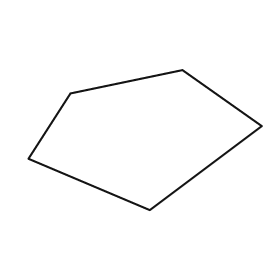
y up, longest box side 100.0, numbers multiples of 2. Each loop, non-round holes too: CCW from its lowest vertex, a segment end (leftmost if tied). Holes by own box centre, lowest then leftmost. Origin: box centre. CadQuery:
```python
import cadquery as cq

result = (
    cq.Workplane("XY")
    .moveTo(2.0, -30.0)
    .lineTo(50.0, 6.0)
    .lineTo(16.0, 30.0)
    .lineTo(-32.0, 20.0)
    .lineTo(-50.0, -8.0)
    .close()
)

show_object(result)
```